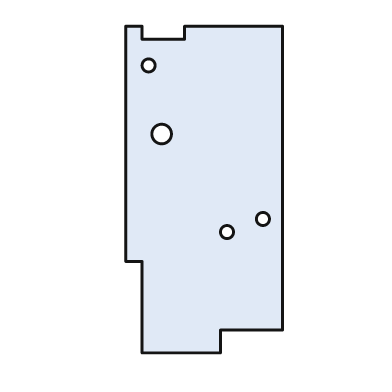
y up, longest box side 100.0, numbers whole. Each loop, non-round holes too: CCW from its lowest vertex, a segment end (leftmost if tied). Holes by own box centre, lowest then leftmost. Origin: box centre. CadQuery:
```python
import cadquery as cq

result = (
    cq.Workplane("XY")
    .moveTo(-19.0, -50.0)
    .lineTo(5.0, -50.0)
    .lineTo(5.0, -43.0)
    .lineTo(24.0, -43.0)
    .lineTo(24.0, 50.0)
    .lineTo(-6.0, 50.0)
    .lineTo(-6.0, 46.0)
    .lineTo(-19.0, 46.0)
    .lineTo(-19.0, 50.0)
    .lineTo(-24.0, 50.0)
    .lineTo(-24.0, -22.0)
    .lineTo(-19.0, -22.0)
    .close()
    .moveTo(7.0, -13.0)
    .circle(2.0)
    .moveTo(18.0, -9.0)
    .circle(2.0)
    .moveTo(-13.0, 17.0)
    .circle(3.0)
    .moveTo(-17.0, 38.0)
    .circle(2.0)
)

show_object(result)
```